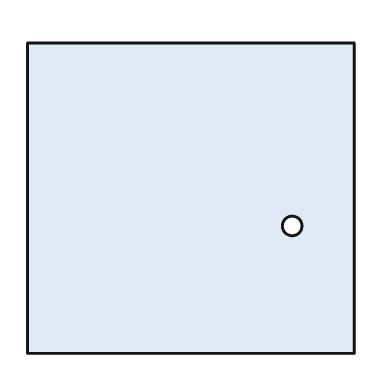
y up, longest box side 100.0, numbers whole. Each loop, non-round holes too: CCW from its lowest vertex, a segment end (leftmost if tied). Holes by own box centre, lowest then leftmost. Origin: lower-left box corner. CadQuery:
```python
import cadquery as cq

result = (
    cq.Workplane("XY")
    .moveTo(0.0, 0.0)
    .lineTo(100.0, 0.0)
    .lineTo(100.0, 95.0)
    .lineTo(0.0, 95.0)
    .close()
    .moveTo(81.0, 39.0)
    .circle(3.0)
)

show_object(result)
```